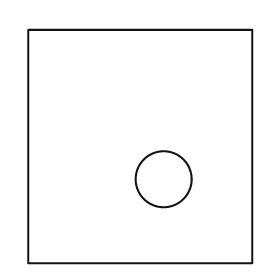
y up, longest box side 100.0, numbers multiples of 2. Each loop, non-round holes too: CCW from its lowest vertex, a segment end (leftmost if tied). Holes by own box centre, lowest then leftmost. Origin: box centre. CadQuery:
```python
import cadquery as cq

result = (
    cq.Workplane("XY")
    .moveTo(-48.0, -50.0)
    .lineTo(48.0, -50.0)
    .lineTo(48.0, 50.0)
    .lineTo(-48.0, 50.0)
    .close()
    .moveTo(10.0, -14.0)
    .circle(12.0)
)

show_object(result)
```